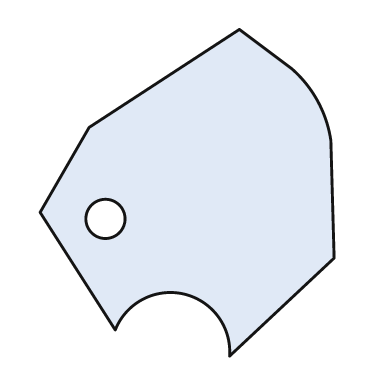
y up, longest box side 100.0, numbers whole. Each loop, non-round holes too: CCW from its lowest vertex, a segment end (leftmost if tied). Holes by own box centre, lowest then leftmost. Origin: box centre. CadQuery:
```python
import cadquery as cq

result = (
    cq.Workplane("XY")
    .moveTo(13.0, -50.0)
    .lineTo(45.0, -20.0)
    .lineTo(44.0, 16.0)
    .threePointArc((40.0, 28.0), (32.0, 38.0))
    .lineTo(16.0, 50.0)
    .lineTo(-30.0, 20.0)
    .lineTo(-45.0, -6.0)
    .lineTo(-22.0, -42.0)
    .threePointArc((-1.0, -31.0), (13.0, -50.0))
    .close()
    .moveTo(-25.0, -8.0)
    .circle(6.0)
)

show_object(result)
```